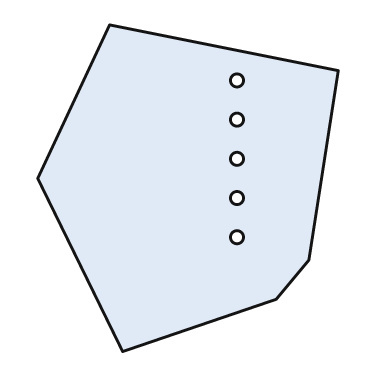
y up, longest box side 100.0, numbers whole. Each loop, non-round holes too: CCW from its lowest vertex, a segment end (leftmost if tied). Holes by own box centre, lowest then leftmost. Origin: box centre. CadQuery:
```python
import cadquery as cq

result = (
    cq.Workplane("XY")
    .moveTo(-20.0, -50.0)
    .lineTo(27.0, -34.0)
    .lineTo(37.0, -22.0)
    .lineTo(46.0, 36.0)
    .lineTo(-24.0, 50.0)
    .lineTo(-46.0, 3.0)
    .close()
    .moveTo(15.0, -15.0)
    .circle(2.0)
    .moveTo(15.0, -3.0)
    .circle(2.0)
    .moveTo(15.0, 9.0)
    .circle(2.0)
    .moveTo(15.0, 21.0)
    .circle(2.0)
    .moveTo(15.0, 33.0)
    .circle(2.0)
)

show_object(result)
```